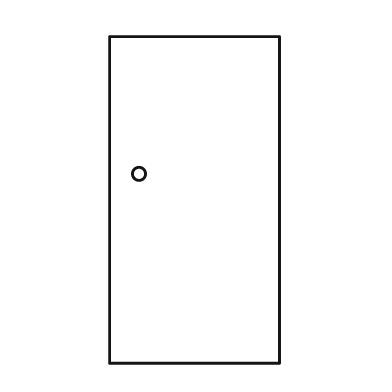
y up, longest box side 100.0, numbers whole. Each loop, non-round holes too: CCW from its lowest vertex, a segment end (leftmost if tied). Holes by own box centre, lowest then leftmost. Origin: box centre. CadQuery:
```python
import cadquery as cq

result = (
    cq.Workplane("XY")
    .moveTo(-26.0, -50.0)
    .lineTo(26.0, -50.0)
    .lineTo(26.0, 50.0)
    .lineTo(-26.0, 50.0)
    .close()
    .moveTo(-17.0, 8.0)
    .circle(2.0)
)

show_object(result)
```